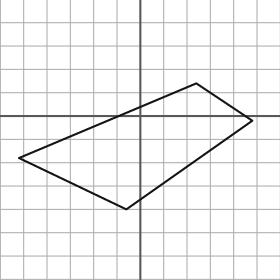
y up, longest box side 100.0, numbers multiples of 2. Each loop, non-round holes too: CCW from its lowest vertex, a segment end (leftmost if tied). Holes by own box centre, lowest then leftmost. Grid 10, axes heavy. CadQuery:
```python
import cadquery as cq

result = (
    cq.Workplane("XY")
    .moveTo(-6.0, -40.0)
    .lineTo(48.0, -2.0)
    .lineTo(24.0, 14.0)
    .lineTo(-52.0, -18.0)
    .close()
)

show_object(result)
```